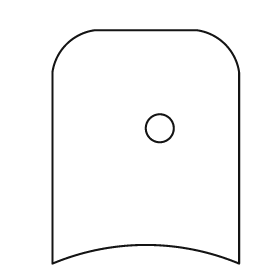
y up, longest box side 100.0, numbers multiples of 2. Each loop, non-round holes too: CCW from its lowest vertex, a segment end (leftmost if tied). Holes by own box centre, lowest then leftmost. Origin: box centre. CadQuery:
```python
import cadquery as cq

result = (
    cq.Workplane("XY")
    .moveTo(-40.0, -50.0)
    .threePointArc((0.0, -42.0), (40.0, -50.0))
    .lineTo(40.0, 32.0)
    .threePointArc((34.0, 44.0), (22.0, 50.0))
    .lineTo(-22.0, 50.0)
    .threePointArc((-34.0, 44.0), (-40.0, 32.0))
    .close()
    .moveTo(6.0, 8.0)
    .circle(6.0)
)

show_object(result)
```